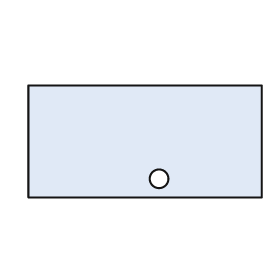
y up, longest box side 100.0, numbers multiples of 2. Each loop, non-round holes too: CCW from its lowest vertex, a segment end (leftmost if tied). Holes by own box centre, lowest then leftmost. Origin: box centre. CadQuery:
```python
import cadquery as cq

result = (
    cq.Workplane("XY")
    .moveTo(-50.0, -24.0)
    .lineTo(50.0, -24.0)
    .lineTo(50.0, 24.0)
    .lineTo(-50.0, 24.0)
    .close()
    .moveTo(6.0, -16.0)
    .circle(4.0)
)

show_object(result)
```